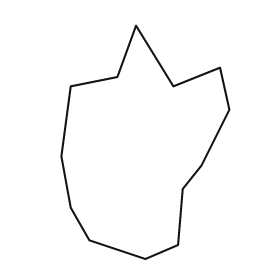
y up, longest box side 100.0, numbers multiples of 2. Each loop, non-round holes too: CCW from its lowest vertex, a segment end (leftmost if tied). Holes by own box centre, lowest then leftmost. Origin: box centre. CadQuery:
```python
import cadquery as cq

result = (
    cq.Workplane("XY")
    .moveTo(0.0, -50.0)
    .lineTo(14.0, -44.0)
    .lineTo(16.0, -20.0)
    .lineTo(24.0, -10.0)
    .lineTo(36.0, 14.0)
    .lineTo(32.0, 32.0)
    .lineTo(12.0, 24.0)
    .lineTo(-4.0, 50.0)
    .lineTo(-12.0, 28.0)
    .lineTo(-32.0, 24.0)
    .lineTo(-36.0, -6.0)
    .lineTo(-32.0, -28.0)
    .lineTo(-24.0, -42.0)
    .close()
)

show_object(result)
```